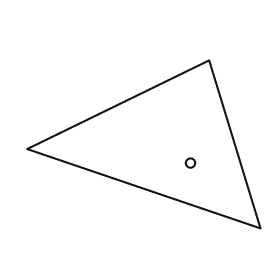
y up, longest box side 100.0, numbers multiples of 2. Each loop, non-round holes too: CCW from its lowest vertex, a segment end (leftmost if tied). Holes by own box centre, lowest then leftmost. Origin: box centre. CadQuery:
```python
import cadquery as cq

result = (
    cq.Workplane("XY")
    .moveTo(50.0, -36.0)
    .lineTo(28.0, 36.0)
    .lineTo(-50.0, -2.0)
    .close()
    .moveTo(20.0, -8.0)
    .circle(2.0)
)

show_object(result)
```